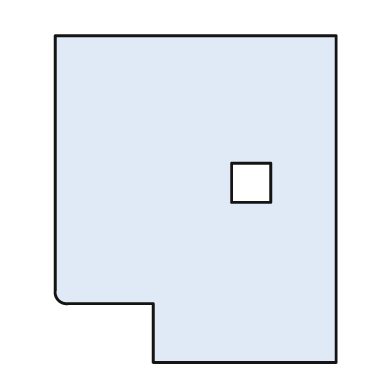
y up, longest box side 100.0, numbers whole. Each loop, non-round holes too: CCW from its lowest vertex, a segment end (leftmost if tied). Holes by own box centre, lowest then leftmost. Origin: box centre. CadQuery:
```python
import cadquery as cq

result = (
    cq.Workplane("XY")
    .moveTo(-13.0, -50.0)
    .lineTo(43.0, -50.0)
    .lineTo(43.0, 50.0)
    .lineTo(-43.0, 50.0)
    .lineTo(-43.0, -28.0)
    .threePointArc((-42.0, -31.0), (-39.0, -32.0))
    .lineTo(-13.0, -32.0)
    .close()
    .moveTo(11.0, -1.0)
    .lineTo(23.0, -1.0)
    .lineTo(23.0, 11.0)
    .lineTo(11.0, 11.0)
    .close()
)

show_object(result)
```